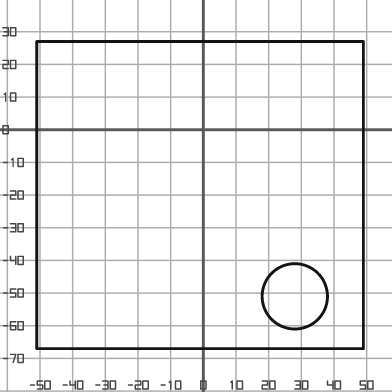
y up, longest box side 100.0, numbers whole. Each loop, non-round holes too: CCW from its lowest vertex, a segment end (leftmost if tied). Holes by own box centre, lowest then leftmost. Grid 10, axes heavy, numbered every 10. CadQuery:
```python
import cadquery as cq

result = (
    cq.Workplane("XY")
    .moveTo(-51.0, -67.0)
    .lineTo(49.0, -67.0)
    .lineTo(49.0, 27.0)
    .lineTo(-51.0, 27.0)
    .close()
    .moveTo(28.0, -51.0)
    .circle(10.0)
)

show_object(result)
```